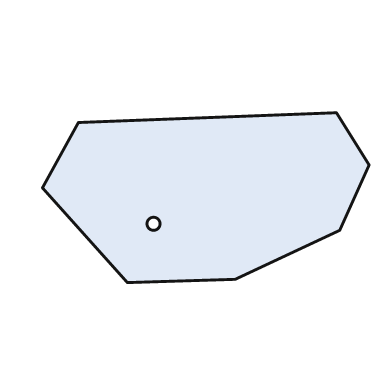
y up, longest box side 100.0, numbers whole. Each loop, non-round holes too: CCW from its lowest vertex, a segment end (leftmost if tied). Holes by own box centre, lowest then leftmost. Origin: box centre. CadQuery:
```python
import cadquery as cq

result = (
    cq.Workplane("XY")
    .moveTo(-24.0, -26.0)
    .lineTo(9.0, -25.0)
    .lineTo(41.0, -10.0)
    .lineTo(50.0, 10.0)
    .lineTo(40.0, 26.0)
    .lineTo(-39.0, 23.0)
    .lineTo(-50.0, 3.0)
    .close()
    .moveTo(-16.0, -8.0)
    .circle(2.0)
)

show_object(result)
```